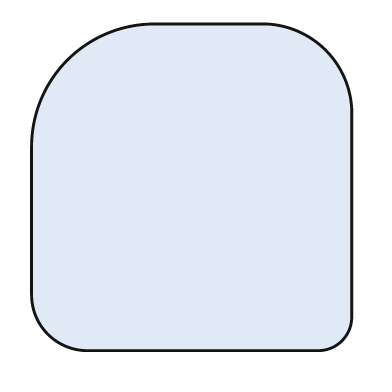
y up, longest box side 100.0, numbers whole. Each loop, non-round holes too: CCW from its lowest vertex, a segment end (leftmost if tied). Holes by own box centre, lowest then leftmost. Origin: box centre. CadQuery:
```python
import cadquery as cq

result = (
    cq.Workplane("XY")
    .moveTo(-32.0, -50.0)
    .lineTo(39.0, -50.0)
    .threePointArc((46.0, -47.0), (49.0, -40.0))
    .lineTo(49.0, 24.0)
    .threePointArc((41.0, 42.0), (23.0, 50.0))
    .lineTo(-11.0, 50.0)
    .threePointArc((-38.0, 39.0), (-49.0, 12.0))
    .lineTo(-49.0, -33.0)
    .threePointArc((-44.0, -45.0), (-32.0, -50.0))
    .close()
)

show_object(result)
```